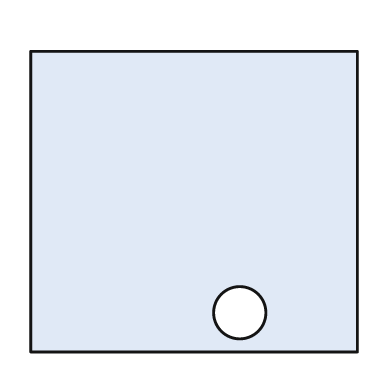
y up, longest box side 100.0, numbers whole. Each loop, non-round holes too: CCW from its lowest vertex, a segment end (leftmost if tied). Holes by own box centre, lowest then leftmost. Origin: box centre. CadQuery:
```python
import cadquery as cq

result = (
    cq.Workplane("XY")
    .moveTo(-50.0, -46.0)
    .lineTo(50.0, -46.0)
    .lineTo(50.0, 46.0)
    .lineTo(-50.0, 46.0)
    .close()
    .moveTo(14.0, -34.0)
    .circle(8.0)
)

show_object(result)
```